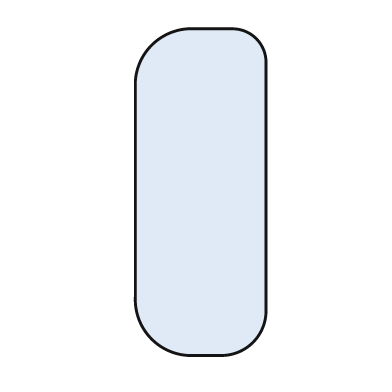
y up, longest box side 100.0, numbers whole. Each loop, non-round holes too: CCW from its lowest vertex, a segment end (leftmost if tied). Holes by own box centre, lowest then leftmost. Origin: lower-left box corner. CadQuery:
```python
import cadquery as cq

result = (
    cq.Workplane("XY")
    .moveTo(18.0, 0.0)
    .lineTo(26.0, 0.0)
    .threePointArc((36.0, 4.0), (40.0, 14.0))
    .lineTo(40.0, 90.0)
    .threePointArc((37.0, 97.0), (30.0, 100.0))
    .lineTo(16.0, 100.0)
    .threePointArc((5.0, 95.0), (0.0, 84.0))
    .lineTo(0.0, 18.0)
    .threePointArc((5.0, 5.0), (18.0, 0.0))
    .close()
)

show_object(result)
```